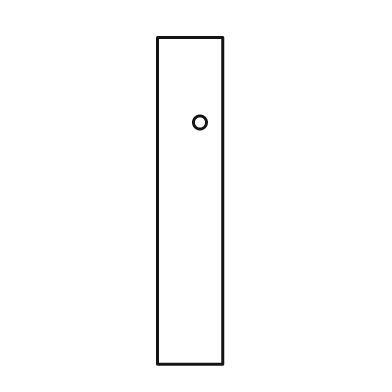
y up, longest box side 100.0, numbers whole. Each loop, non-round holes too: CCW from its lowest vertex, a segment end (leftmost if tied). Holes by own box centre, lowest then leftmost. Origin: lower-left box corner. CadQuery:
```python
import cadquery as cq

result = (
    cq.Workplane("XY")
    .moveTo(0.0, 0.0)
    .lineTo(20.0, 0.0)
    .lineTo(20.0, 100.0)
    .lineTo(0.0, 100.0)
    .close()
    .moveTo(13.0, 74.0)
    .circle(2.0)
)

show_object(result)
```